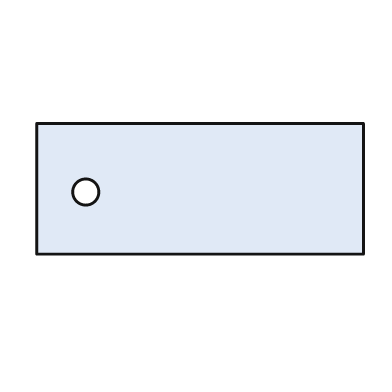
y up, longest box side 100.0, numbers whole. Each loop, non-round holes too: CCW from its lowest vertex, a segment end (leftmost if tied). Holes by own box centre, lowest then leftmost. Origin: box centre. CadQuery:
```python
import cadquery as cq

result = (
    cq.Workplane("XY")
    .moveTo(-50.0, -20.0)
    .lineTo(50.0, -20.0)
    .lineTo(50.0, 20.0)
    .lineTo(-50.0, 20.0)
    .close()
    .moveTo(-35.0, -1.0)
    .circle(4.0)
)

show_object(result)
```